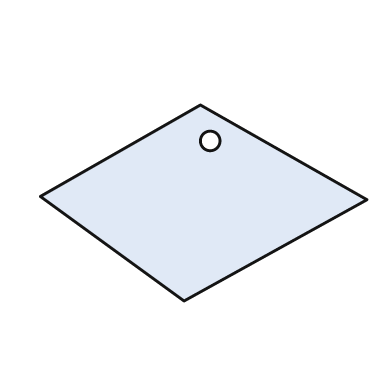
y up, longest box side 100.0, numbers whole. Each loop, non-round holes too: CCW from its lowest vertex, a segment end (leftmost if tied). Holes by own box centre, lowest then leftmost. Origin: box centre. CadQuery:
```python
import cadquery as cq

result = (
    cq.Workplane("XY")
    .moveTo(-6.0, -30.0)
    .lineTo(50.0, 1.0)
    .lineTo(-1.0, 30.0)
    .lineTo(-50.0, 2.0)
    .close()
    .moveTo(2.0, 19.0)
    .circle(3.0)
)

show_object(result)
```